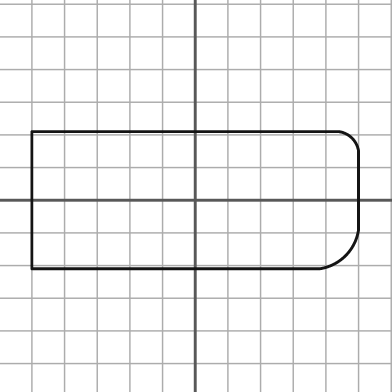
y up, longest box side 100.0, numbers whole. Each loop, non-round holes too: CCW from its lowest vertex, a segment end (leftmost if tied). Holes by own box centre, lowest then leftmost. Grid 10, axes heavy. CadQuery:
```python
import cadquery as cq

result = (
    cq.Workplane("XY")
    .moveTo(-50.0, -21.0)
    .lineTo(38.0, -21.0)
    .threePointArc((46.0, -17.0), (50.0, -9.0))
    .lineTo(50.0, 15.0)
    .threePointArc((48.0, 19.0), (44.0, 21.0))
    .lineTo(-50.0, 21.0)
    .close()
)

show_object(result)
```